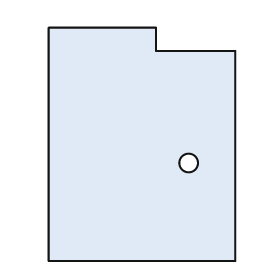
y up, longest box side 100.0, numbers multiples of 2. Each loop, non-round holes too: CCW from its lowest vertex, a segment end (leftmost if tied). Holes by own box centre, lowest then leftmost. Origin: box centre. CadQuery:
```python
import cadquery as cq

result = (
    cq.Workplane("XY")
    .moveTo(-40.0, -50.0)
    .lineTo(40.0, -50.0)
    .lineTo(40.0, 40.0)
    .lineTo(6.0, 40.0)
    .lineTo(6.0, 50.0)
    .lineTo(-40.0, 50.0)
    .close()
    .moveTo(20.0, -8.0)
    .circle(4.0)
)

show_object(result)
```